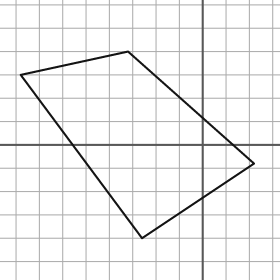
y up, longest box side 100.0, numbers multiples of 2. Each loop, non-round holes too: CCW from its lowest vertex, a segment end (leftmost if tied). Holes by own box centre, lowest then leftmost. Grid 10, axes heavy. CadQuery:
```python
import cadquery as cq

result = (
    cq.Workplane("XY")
    .moveTo(-26.0, -40.0)
    .lineTo(22.0, -8.0)
    .lineTo(-32.0, 40.0)
    .lineTo(-78.0, 30.0)
    .close()
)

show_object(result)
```